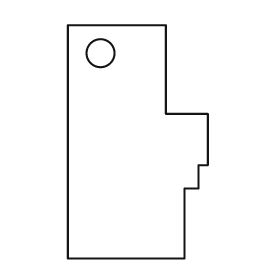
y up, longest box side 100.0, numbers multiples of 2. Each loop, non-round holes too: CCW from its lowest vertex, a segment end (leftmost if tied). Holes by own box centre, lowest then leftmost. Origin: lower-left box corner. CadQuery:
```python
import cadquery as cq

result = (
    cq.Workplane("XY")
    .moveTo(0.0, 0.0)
    .lineTo(50.0, 0.0)
    .lineTo(50.0, 30.0)
    .lineTo(56.0, 30.0)
    .lineTo(56.0, 40.0)
    .lineTo(60.0, 40.0)
    .lineTo(60.0, 62.0)
    .lineTo(42.0, 62.0)
    .lineTo(42.0, 100.0)
    .lineTo(0.0, 100.0)
    .close()
    .moveTo(14.0, 88.0)
    .circle(6.0)
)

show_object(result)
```